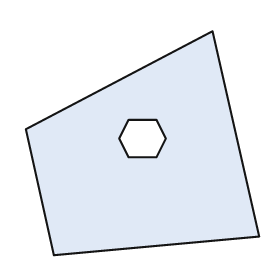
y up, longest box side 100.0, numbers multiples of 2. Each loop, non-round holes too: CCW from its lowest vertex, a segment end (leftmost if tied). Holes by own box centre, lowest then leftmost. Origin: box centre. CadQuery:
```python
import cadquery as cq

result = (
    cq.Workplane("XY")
    .moveTo(-38.0, -48.0)
    .lineTo(50.0, -40.0)
    .lineTo(30.0, 48.0)
    .lineTo(-50.0, 6.0)
    .close()
    .moveTo(-6.0, -6.0)
    .lineTo(6.0, -6.0)
    .lineTo(10.0, 2.0)
    .lineTo(6.0, 10.0)
    .lineTo(-6.0, 10.0)
    .lineTo(-10.0, 2.0)
    .close()
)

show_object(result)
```